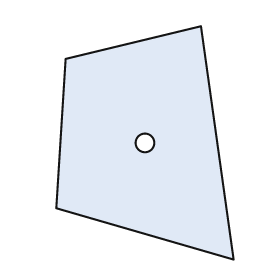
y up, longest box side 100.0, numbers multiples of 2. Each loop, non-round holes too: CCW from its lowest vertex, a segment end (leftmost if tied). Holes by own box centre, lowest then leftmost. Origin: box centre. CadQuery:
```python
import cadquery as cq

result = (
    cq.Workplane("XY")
    .moveTo(38.0, -50.0)
    .lineTo(24.0, 50.0)
    .lineTo(-34.0, 36.0)
    .lineTo(-38.0, -28.0)
    .close()
    .moveTo(0.0, 0.0)
    .circle(4.0)
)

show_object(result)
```